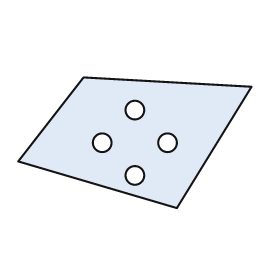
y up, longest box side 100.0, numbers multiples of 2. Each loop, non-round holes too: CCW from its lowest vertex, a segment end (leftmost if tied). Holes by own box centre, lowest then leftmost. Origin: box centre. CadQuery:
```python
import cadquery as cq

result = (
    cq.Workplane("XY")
    .moveTo(18.0, -28.0)
    .lineTo(50.0, 24.0)
    .lineTo(-22.0, 28.0)
    .lineTo(-50.0, -8.0)
    .close()
    .moveTo(0.0, -14.0)
    .circle(4.0)
    .moveTo(-14.0, 0.0)
    .circle(4.0)
    .moveTo(14.0, 0.0)
    .circle(4.0)
    .moveTo(0.0, 14.0)
    .circle(4.0)
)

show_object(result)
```